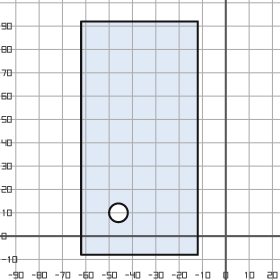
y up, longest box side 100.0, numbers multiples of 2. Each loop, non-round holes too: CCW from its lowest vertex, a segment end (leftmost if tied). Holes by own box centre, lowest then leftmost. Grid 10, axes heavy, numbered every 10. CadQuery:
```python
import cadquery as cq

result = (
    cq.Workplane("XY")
    .moveTo(-62.0, -8.0)
    .lineTo(-12.0, -8.0)
    .lineTo(-12.0, 92.0)
    .lineTo(-62.0, 92.0)
    .close()
    .moveTo(-46.0, 10.0)
    .circle(4.0)
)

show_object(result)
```